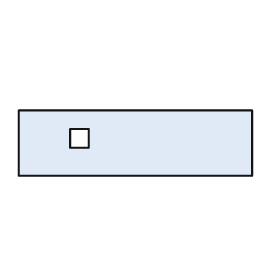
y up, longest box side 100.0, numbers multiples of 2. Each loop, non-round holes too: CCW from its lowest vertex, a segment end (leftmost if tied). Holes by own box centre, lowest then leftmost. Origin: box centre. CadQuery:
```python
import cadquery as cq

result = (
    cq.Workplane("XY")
    .moveTo(-50.0, -14.0)
    .lineTo(50.0, -14.0)
    .lineTo(50.0, 14.0)
    .lineTo(-50.0, 14.0)
    .close()
    .moveTo(-28.0, -2.0)
    .lineTo(-20.0, -2.0)
    .lineTo(-20.0, 6.0)
    .lineTo(-28.0, 6.0)
    .close()
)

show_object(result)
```